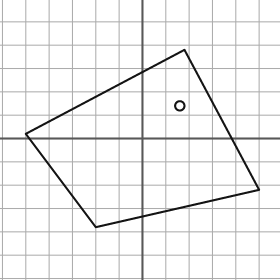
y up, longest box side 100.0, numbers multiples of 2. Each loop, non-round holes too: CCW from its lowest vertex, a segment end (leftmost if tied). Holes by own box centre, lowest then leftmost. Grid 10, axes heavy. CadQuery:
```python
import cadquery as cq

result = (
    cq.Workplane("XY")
    .moveTo(-20.0, -38.0)
    .lineTo(50.0, -22.0)
    .lineTo(18.0, 38.0)
    .lineTo(-50.0, 2.0)
    .close()
    .moveTo(16.0, 14.0)
    .circle(2.0)
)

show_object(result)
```